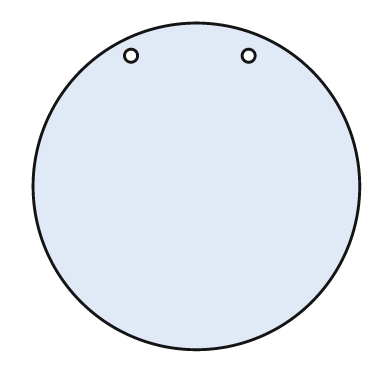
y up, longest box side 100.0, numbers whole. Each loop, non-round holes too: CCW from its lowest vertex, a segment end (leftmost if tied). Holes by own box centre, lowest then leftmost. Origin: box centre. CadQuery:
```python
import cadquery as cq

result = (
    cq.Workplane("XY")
    .moveTo(0.0, 0.0)
    .circle(50.0)
    .moveTo(-20.0, 40.0)
    .circle(2.0)
    .moveTo(16.0, 40.0)
    .circle(2.0)
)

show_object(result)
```